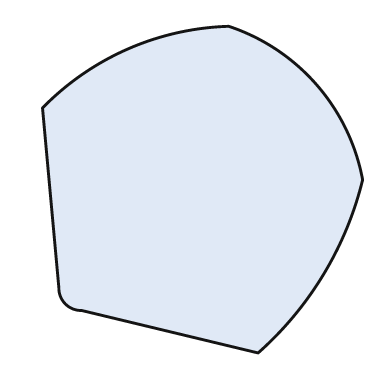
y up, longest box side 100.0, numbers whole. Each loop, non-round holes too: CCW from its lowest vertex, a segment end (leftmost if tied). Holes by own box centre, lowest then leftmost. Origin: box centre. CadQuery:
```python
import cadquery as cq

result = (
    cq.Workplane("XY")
    .moveTo(17.0, -50.0)
    .threePointArc((37.0, -26.0), (49.0, 3.0))
    .threePointArc((35.0, 32.0), (8.0, 50.0))
    .threePointArc((-23.0, 43.0), (-49.0, 25.0))
    .lineTo(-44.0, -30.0)
    .threePointArc((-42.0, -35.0), (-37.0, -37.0))
    .close()
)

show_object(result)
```